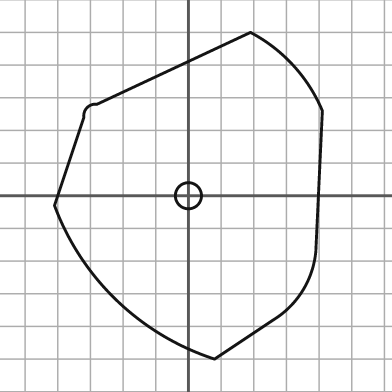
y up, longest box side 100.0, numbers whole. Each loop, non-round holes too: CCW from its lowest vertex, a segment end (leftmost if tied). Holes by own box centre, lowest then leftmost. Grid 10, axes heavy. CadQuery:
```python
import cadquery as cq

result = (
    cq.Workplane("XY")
    .moveTo(8.0, -50.0)
    .lineTo(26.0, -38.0)
    .threePointArc((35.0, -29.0), (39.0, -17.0))
    .lineTo(41.0, 26.0)
    .threePointArc((32.0, 40.0), (19.0, 50.0))
    .lineTo(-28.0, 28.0)
    .threePointArc((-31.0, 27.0), (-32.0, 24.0))
    .lineTo(-41.0, -3.0)
    .threePointArc((-22.0, -32.0), (8.0, -50.0))
    .close()
    .moveTo(0.0, 0.0)
    .circle(4.0)
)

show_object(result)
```